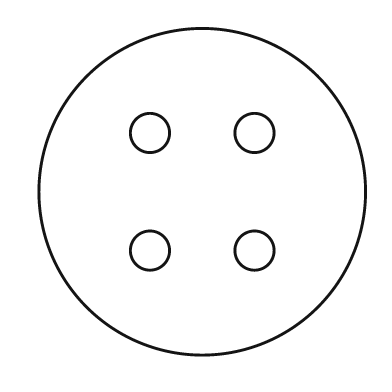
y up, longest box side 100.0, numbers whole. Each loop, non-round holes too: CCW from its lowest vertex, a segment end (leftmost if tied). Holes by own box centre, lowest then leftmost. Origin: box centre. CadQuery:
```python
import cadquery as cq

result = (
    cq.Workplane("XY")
    .moveTo(0.0, 0.0)
    .circle(50.0)
    .moveTo(-16.0, -18.0)
    .circle(6.0)
    .moveTo(16.0, -18.0)
    .circle(6.0)
    .moveTo(-16.0, 18.0)
    .circle(6.0)
    .moveTo(16.0, 18.0)
    .circle(6.0)
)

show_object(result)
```